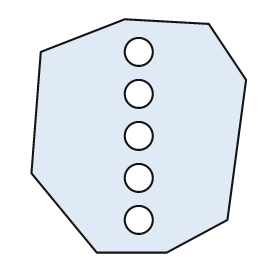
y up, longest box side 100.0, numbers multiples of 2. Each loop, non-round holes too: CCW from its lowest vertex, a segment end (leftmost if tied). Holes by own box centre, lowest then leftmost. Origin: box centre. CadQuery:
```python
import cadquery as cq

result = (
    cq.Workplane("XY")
    .moveTo(-18.0, -50.0)
    .lineTo(12.0, -50.0)
    .lineTo(38.0, -36.0)
    .lineTo(46.0, 24.0)
    .lineTo(30.0, 48.0)
    .lineTo(-6.0, 50.0)
    .lineTo(-42.0, 36.0)
    .lineTo(-46.0, -16.0)
    .close()
    .moveTo(0.0, -36.0)
    .circle(6.0)
    .moveTo(0.0, -18.0)
    .circle(6.0)
    .moveTo(0.0, 0.0)
    .circle(6.0)
    .moveTo(0.0, 18.0)
    .circle(6.0)
    .moveTo(0.0, 36.0)
    .circle(6.0)
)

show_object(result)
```